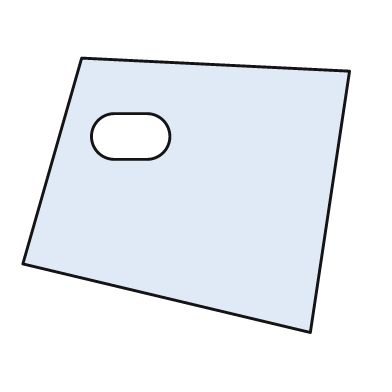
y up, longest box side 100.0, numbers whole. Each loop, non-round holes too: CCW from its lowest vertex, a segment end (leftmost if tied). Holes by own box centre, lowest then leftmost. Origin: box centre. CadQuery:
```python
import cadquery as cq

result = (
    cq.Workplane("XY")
    .moveTo(38.0, -42.0)
    .lineTo(50.0, 38.0)
    .lineTo(-32.0, 42.0)
    .lineTo(-50.0, -21.0)
    .close()
    .moveTo(-22.0, 11.0)
    .lineTo(-12.0, 11.0)
    .threePointArc((-5.0, 18.0), (-12.0, 25.0))
    .lineTo(-22.0, 25.0)
    .threePointArc((-29.0, 18.0), (-22.0, 11.0))
    .close()
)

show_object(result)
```